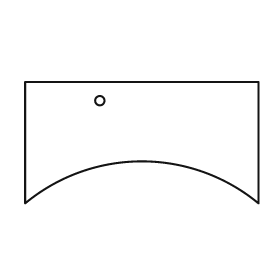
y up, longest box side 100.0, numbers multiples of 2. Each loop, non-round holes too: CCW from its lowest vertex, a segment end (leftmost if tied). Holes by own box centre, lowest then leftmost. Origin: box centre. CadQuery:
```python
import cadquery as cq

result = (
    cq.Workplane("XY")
    .moveTo(-50.0, -26.0)
    .threePointArc((0.0, -8.0), (50.0, -26.0))
    .lineTo(50.0, 26.0)
    .lineTo(-50.0, 26.0)
    .close()
    .moveTo(-18.0, 18.0)
    .circle(2.0)
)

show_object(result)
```